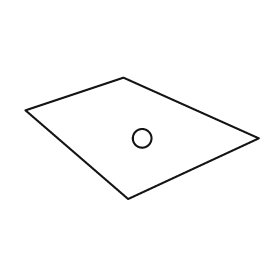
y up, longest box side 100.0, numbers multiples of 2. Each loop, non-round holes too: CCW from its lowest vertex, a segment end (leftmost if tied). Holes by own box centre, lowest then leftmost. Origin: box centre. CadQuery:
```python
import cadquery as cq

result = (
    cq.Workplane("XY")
    .moveTo(-6.0, -26.0)
    .lineTo(50.0, 0.0)
    .lineTo(-8.0, 26.0)
    .lineTo(-50.0, 12.0)
    .close()
    .moveTo(0.0, 0.0)
    .circle(4.0)
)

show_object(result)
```